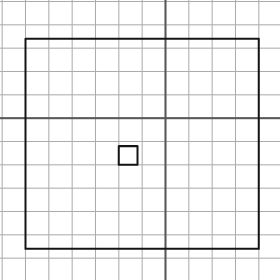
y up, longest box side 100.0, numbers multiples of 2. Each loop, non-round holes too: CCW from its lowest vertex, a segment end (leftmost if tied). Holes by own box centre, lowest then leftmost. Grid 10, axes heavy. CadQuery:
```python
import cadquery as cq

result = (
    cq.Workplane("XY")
    .moveTo(-60.0, -56.0)
    .lineTo(40.0, -56.0)
    .lineTo(40.0, 34.0)
    .lineTo(-60.0, 34.0)
    .close()
    .moveTo(-20.0, -20.0)
    .lineTo(-12.0, -20.0)
    .lineTo(-12.0, -12.0)
    .lineTo(-20.0, -12.0)
    .close()
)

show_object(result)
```